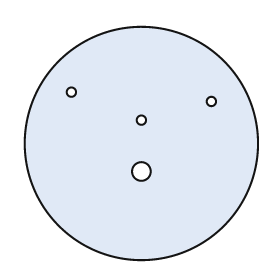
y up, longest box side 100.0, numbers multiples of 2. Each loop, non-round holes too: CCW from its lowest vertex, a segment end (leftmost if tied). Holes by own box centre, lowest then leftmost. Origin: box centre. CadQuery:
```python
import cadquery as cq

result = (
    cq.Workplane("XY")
    .moveTo(0.0, 0.0)
    .circle(50.0)
    .moveTo(0.0, -12.0)
    .circle(4.0)
    .moveTo(0.0, 10.0)
    .circle(2.0)
    .moveTo(30.0, 18.0)
    .circle(2.0)
    .moveTo(-30.0, 22.0)
    .circle(2.0)
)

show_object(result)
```